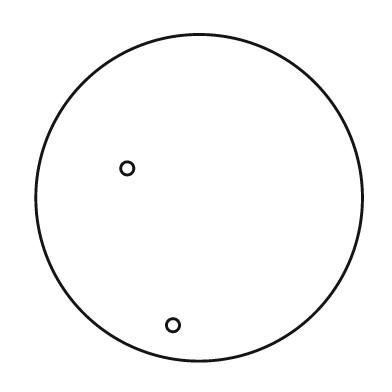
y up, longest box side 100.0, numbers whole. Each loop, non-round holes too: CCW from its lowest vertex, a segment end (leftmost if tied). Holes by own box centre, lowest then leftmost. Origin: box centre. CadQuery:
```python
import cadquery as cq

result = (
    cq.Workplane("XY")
    .moveTo(0.0, 0.0)
    .circle(50.0)
    .moveTo(-8.0, -39.0)
    .circle(2.0)
    .moveTo(-22.0, 9.0)
    .circle(2.0)
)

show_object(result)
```